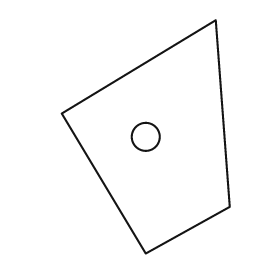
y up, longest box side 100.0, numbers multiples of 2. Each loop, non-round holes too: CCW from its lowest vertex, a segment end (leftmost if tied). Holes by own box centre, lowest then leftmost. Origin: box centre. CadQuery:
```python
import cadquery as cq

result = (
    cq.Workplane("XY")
    .moveTo(0.0, -50.0)
    .lineTo(36.0, -30.0)
    .lineTo(30.0, 50.0)
    .lineTo(-36.0, 10.0)
    .close()
    .moveTo(0.0, 0.0)
    .circle(6.0)
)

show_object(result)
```